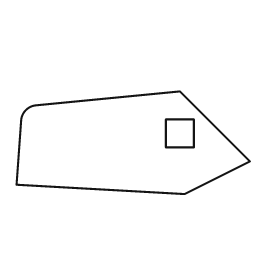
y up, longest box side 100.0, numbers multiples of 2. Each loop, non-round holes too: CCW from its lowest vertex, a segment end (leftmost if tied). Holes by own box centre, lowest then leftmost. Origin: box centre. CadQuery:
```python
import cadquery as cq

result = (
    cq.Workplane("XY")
    .moveTo(22.0, -22.0)
    .lineTo(50.0, -8.0)
    .lineTo(20.0, 22.0)
    .lineTo(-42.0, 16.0)
    .threePointArc((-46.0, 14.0), (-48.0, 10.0))
    .lineTo(-50.0, -18.0)
    .close()
    .moveTo(14.0, -2.0)
    .lineTo(26.0, -2.0)
    .lineTo(26.0, 10.0)
    .lineTo(14.0, 10.0)
    .close()
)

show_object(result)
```